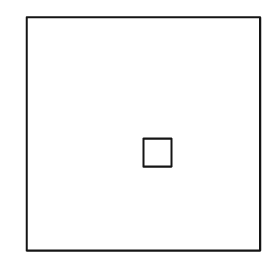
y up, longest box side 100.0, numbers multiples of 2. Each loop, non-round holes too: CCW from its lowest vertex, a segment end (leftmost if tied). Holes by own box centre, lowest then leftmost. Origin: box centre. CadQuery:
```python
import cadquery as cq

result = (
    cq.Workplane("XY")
    .moveTo(-50.0, -50.0)
    .lineTo(50.0, -50.0)
    .lineTo(50.0, 50.0)
    .lineTo(-50.0, 50.0)
    .close()
    .moveTo(0.0, -14.0)
    .lineTo(12.0, -14.0)
    .lineTo(12.0, -2.0)
    .lineTo(0.0, -2.0)
    .close()
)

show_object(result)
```